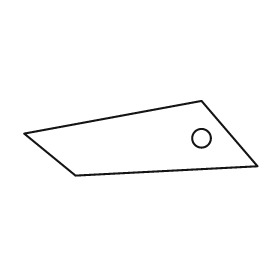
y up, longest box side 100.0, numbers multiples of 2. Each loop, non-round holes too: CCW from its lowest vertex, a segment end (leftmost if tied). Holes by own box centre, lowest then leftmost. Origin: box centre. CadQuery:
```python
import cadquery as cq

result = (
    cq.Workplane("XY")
    .moveTo(-28.0, -16.0)
    .lineTo(50.0, -12.0)
    .lineTo(26.0, 16.0)
    .lineTo(-50.0, 2.0)
    .close()
    .moveTo(26.0, 0.0)
    .circle(4.0)
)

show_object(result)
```